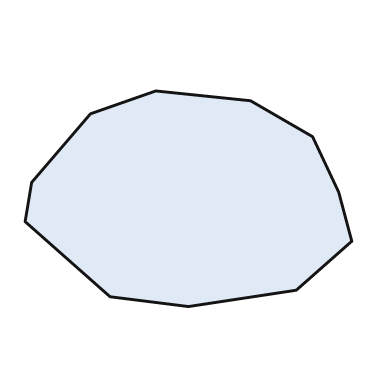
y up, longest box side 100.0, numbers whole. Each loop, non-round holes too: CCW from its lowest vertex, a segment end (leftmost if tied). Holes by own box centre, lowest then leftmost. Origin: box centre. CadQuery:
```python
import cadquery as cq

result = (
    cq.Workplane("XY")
    .moveTo(0.0, -33.0)
    .lineTo(33.0, -28.0)
    .lineTo(50.0, -13.0)
    .lineTo(46.0, 2.0)
    .lineTo(38.0, 19.0)
    .lineTo(19.0, 30.0)
    .lineTo(-10.0, 33.0)
    .lineTo(-30.0, 26.0)
    .lineTo(-48.0, 5.0)
    .lineTo(-50.0, -7.0)
    .lineTo(-24.0, -30.0)
    .close()
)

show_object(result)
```